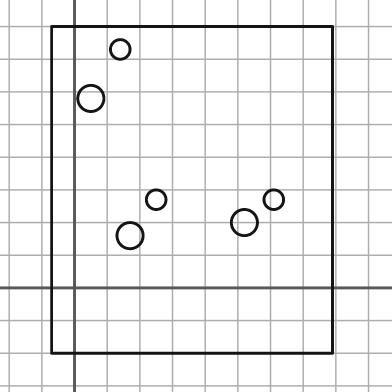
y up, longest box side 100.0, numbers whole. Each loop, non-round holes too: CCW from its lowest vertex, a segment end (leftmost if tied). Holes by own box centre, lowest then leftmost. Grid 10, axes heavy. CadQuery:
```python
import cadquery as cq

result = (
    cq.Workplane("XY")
    .moveTo(-7.0, -20.0)
    .lineTo(79.0, -20.0)
    .lineTo(79.0, 80.0)
    .lineTo(-7.0, 80.0)
    .close()
    .moveTo(17.0, 16.0)
    .circle(4.0)
    .moveTo(52.0, 20.0)
    .circle(4.0)
    .moveTo(25.0, 27.0)
    .circle(3.0)
    .moveTo(61.0, 27.0)
    .circle(3.0)
    .moveTo(5.0, 58.0)
    .circle(4.0)
    .moveTo(14.0, 73.0)
    .circle(3.0)
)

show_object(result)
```